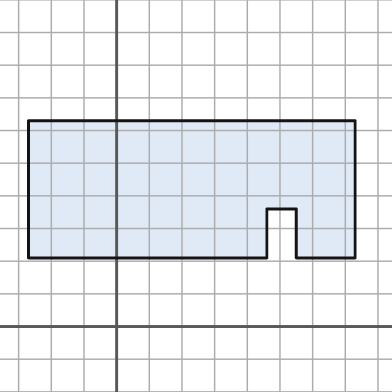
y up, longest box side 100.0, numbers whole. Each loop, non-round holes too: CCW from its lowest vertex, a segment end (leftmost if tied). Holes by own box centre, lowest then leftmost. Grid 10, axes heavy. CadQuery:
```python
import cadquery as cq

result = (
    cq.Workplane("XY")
    .moveTo(-27.0, 21.0)
    .lineTo(46.0, 21.0)
    .lineTo(46.0, 36.0)
    .lineTo(55.0, 36.0)
    .lineTo(55.0, 21.0)
    .lineTo(73.0, 21.0)
    .lineTo(73.0, 63.0)
    .lineTo(-27.0, 63.0)
    .close()
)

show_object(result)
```